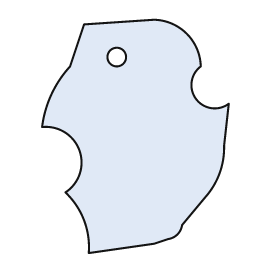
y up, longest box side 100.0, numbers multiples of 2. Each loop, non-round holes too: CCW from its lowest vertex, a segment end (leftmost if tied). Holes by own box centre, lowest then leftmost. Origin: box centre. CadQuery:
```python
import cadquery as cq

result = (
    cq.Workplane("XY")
    .moveTo(-20.0, -50.0)
    .lineTo(8.0, -46.0)
    .lineTo(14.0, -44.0)
    .threePointArc((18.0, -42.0), (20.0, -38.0))
    .lineTo(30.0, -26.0)
    .threePointArc((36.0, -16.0), (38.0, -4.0))
    .lineTo(40.0, 14.0)
    .threePointArc((26.0, 16.0), (28.0, 30.0))
    .threePointArc((22.0, 44.0), (8.0, 50.0))
    .lineTo(-22.0, 48.0)
    .lineTo(-28.0, 30.0)
    .threePointArc((-36.0, 18.0), (-40.0, 4.0))
    .threePointArc((-24.0, -6.0), (-30.0, -24.0))
    .threePointArc((-22.0, -36.0), (-20.0, -50.0))
    .close()
    .moveTo(-8.0, 34.0)
    .circle(4.0)
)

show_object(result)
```